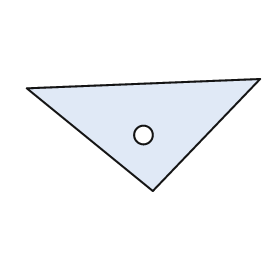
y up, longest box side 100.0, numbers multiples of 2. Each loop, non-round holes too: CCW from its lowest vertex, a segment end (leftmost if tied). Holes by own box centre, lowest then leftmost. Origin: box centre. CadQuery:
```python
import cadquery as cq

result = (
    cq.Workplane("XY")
    .moveTo(4.0, -24.0)
    .lineTo(50.0, 24.0)
    .lineTo(-50.0, 20.0)
    .close()
    .moveTo(0.0, 0.0)
    .circle(4.0)
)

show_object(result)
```